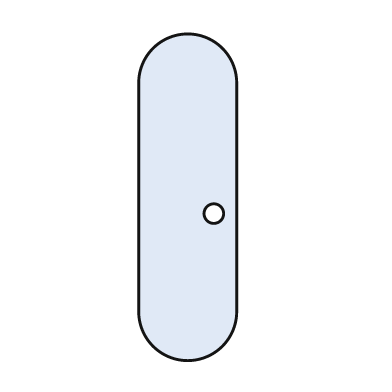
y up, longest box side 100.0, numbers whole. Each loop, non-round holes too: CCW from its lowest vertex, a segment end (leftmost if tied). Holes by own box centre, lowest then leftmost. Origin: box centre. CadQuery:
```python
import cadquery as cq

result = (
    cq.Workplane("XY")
    .moveTo(-15.0, -35.0)
    .threePointArc((0.0, -50.0), (15.0, -35.0))
    .lineTo(15.0, 35.0)
    .threePointArc((0.0, 50.0), (-15.0, 35.0))
    .close()
    .moveTo(8.0, -5.0)
    .circle(3.0)
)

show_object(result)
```